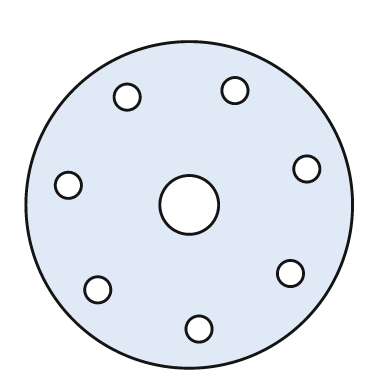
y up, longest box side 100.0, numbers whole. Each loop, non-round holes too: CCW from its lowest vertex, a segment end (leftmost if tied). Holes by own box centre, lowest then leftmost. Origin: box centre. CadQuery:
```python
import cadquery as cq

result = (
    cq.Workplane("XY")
    .moveTo(0.0, 0.0)
    .circle(50.0)
    .moveTo(3.0, -38.0)
    .circle(4.0)
    .moveTo(-28.0, -26.0)
    .circle(4.0)
    .moveTo(31.0, -21.0)
    .circle(4.0)
    .moveTo(0.0, 0.0)
    .circle(9.0)
    .moveTo(-37.0, 6.0)
    .circle(4.0)
    .moveTo(36.0, 11.0)
    .circle(4.0)
    .moveTo(-19.0, 33.0)
    .circle(4.0)
    .moveTo(14.0, 35.0)
    .circle(4.0)
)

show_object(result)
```